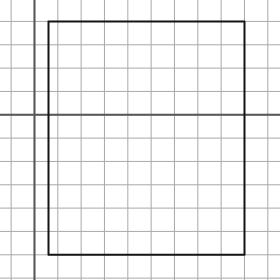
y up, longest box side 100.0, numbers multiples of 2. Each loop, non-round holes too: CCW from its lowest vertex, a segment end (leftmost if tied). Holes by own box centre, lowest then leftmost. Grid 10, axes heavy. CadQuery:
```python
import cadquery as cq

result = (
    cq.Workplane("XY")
    .moveTo(6.0, -60.0)
    .lineTo(90.0, -60.0)
    .lineTo(90.0, 40.0)
    .lineTo(6.0, 40.0)
    .close()
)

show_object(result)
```